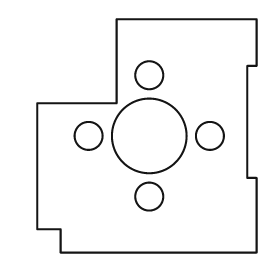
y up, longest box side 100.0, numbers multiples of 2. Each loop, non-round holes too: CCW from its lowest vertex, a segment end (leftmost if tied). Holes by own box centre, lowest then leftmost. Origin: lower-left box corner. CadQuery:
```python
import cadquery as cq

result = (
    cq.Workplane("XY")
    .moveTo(10.0, 0.0)
    .lineTo(94.0, 0.0)
    .lineTo(94.0, 32.0)
    .lineTo(90.0, 32.0)
    .lineTo(90.0, 80.0)
    .lineTo(94.0, 80.0)
    .lineTo(94.0, 100.0)
    .lineTo(34.0, 100.0)
    .lineTo(34.0, 64.0)
    .lineTo(0.0, 64.0)
    .lineTo(0.0, 10.0)
    .lineTo(10.0, 10.0)
    .close()
    .moveTo(48.0, 24.0)
    .circle(6.0)
    .moveTo(22.0, 50.0)
    .circle(6.0)
    .moveTo(48.0, 50.0)
    .circle(16.0)
    .moveTo(74.0, 50.0)
    .circle(6.0)
    .moveTo(48.0, 76.0)
    .circle(6.0)
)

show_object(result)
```